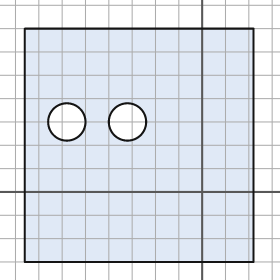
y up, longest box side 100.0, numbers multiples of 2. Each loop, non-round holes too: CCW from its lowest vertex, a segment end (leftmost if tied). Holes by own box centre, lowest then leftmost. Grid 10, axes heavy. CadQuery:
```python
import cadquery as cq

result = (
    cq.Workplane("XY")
    .moveTo(-76.0, -30.0)
    .lineTo(22.0, -30.0)
    .lineTo(22.0, 70.0)
    .lineTo(-76.0, 70.0)
    .close()
    .moveTo(-58.0, 30.0)
    .circle(8.0)
    .moveTo(-32.0, 30.0)
    .circle(8.0)
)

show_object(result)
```